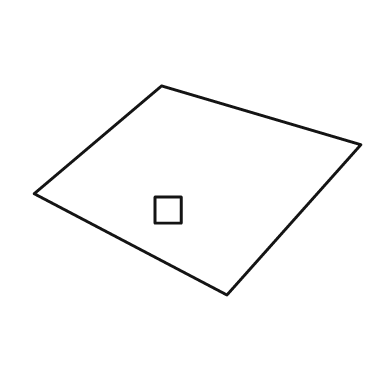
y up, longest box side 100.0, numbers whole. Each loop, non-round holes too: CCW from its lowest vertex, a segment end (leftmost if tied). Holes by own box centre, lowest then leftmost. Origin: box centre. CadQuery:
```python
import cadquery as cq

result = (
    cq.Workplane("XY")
    .moveTo(9.0, -32.0)
    .lineTo(50.0, 14.0)
    .lineTo(-11.0, 32.0)
    .lineTo(-50.0, -1.0)
    .close()
    .moveTo(-13.0, -10.0)
    .lineTo(-5.0, -10.0)
    .lineTo(-5.0, -2.0)
    .lineTo(-13.0, -2.0)
    .close()
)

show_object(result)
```